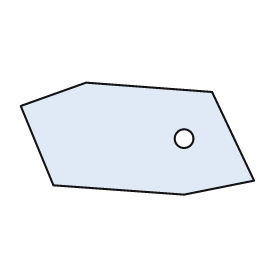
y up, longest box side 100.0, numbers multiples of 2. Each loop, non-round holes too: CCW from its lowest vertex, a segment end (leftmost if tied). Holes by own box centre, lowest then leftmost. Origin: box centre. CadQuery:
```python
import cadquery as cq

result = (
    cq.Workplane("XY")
    .moveTo(20.0, -24.0)
    .lineTo(50.0, -18.0)
    .lineTo(32.0, 20.0)
    .lineTo(-22.0, 24.0)
    .lineTo(-50.0, 14.0)
    .lineTo(-36.0, -20.0)
    .close()
    .moveTo(20.0, 0.0)
    .circle(4.0)
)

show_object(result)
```